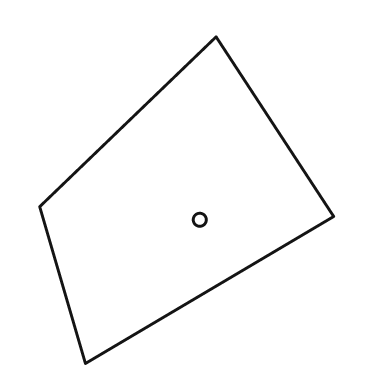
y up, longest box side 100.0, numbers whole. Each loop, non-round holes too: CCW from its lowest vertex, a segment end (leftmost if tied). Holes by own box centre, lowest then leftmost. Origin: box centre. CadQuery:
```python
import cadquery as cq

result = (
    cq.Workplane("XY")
    .moveTo(-31.0, -50.0)
    .lineTo(45.0, -5.0)
    .lineTo(9.0, 50.0)
    .lineTo(-45.0, -2.0)
    .close()
    .moveTo(4.0, -6.0)
    .circle(2.0)
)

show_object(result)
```